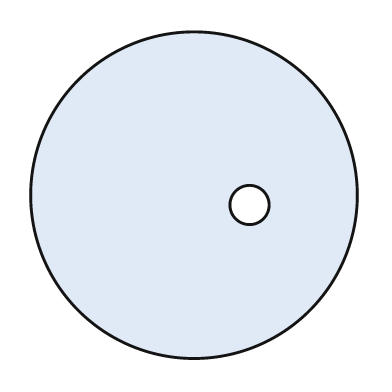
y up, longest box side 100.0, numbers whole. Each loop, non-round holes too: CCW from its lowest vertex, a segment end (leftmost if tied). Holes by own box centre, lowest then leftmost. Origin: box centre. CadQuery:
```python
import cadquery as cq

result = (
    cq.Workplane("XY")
    .moveTo(0.0, 0.0)
    .circle(50.0)
    .moveTo(17.0, -3.0)
    .circle(6.0)
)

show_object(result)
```